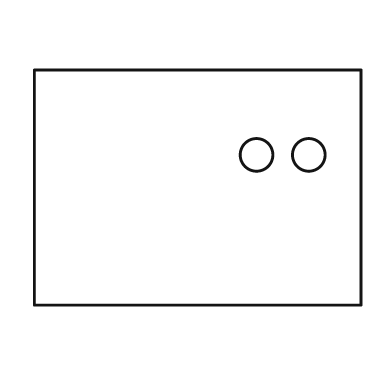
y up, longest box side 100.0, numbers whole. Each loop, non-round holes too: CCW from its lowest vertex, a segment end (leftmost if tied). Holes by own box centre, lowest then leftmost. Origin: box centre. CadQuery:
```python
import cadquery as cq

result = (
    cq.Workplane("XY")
    .moveTo(-50.0, -36.0)
    .lineTo(50.0, -36.0)
    .lineTo(50.0, 36.0)
    .lineTo(-50.0, 36.0)
    .close()
    .moveTo(18.0, 10.0)
    .circle(5.0)
    .moveTo(34.0, 10.0)
    .circle(5.0)
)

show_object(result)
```